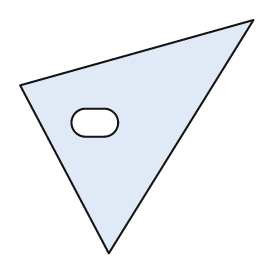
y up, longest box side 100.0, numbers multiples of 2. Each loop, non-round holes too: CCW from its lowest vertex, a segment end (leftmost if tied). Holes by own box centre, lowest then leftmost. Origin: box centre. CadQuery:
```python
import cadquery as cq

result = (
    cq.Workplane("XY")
    .moveTo(-12.0, -50.0)
    .lineTo(50.0, 50.0)
    .lineTo(-50.0, 22.0)
    .close()
    .moveTo(-22.0, 0.0)
    .lineTo(-14.0, 0.0)
    .threePointArc((-8.0, 6.0), (-14.0, 12.0))
    .lineTo(-22.0, 12.0)
    .threePointArc((-28.0, 6.0), (-22.0, 0.0))
    .close()
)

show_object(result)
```